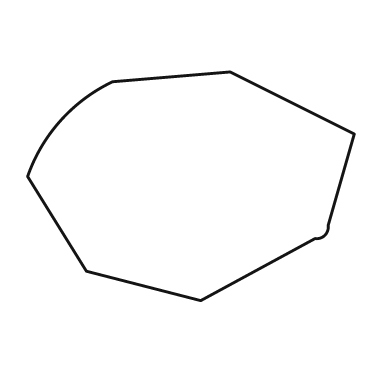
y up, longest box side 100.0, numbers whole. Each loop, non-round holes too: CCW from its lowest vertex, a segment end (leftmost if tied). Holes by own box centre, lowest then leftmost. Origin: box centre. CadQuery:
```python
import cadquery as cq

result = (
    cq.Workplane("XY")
    .moveTo(3.0, -35.0)
    .lineTo(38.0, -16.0)
    .threePointArc((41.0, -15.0), (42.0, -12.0))
    .lineTo(50.0, 16.0)
    .lineTo(12.0, 35.0)
    .lineTo(-24.0, 32.0)
    .threePointArc((-40.0, 20.0), (-50.0, 3.0))
    .lineTo(-32.0, -26.0)
    .close()
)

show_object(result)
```